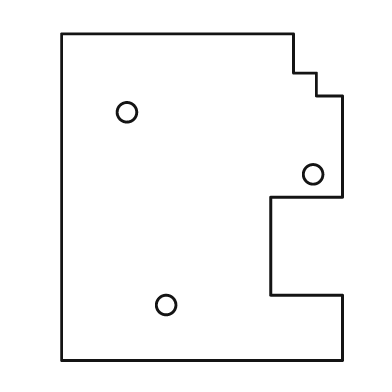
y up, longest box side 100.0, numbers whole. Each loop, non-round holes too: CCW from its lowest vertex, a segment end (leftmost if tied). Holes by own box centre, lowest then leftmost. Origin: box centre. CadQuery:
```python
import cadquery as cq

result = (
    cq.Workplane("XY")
    .moveTo(-43.0, -50.0)
    .lineTo(43.0, -50.0)
    .lineTo(43.0, -30.0)
    .lineTo(21.0, -30.0)
    .lineTo(21.0, 0.0)
    .lineTo(43.0, 0.0)
    .lineTo(43.0, 31.0)
    .lineTo(35.0, 31.0)
    .lineTo(35.0, 38.0)
    .lineTo(28.0, 38.0)
    .lineTo(28.0, 50.0)
    .lineTo(-43.0, 50.0)
    .close()
    .moveTo(-11.0, -33.0)
    .circle(3.0)
    .moveTo(34.0, 7.0)
    .circle(3.0)
    .moveTo(-23.0, 26.0)
    .circle(3.0)
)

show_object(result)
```